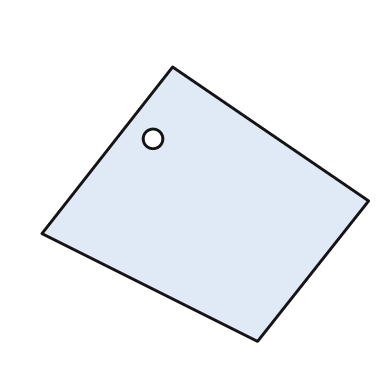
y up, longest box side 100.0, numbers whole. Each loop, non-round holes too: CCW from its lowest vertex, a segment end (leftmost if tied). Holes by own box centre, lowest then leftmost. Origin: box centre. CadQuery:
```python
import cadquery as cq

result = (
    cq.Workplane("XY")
    .moveTo(16.0, -42.0)
    .lineTo(50.0, 1.0)
    .lineTo(-10.0, 42.0)
    .lineTo(-50.0, -9.0)
    .close()
    .moveTo(-16.0, 20.0)
    .circle(3.0)
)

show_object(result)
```